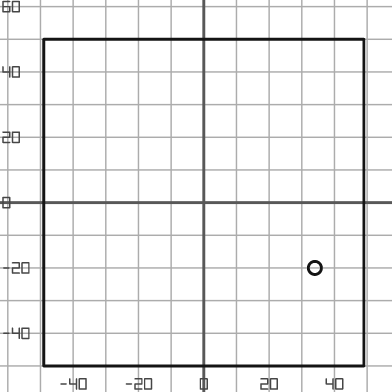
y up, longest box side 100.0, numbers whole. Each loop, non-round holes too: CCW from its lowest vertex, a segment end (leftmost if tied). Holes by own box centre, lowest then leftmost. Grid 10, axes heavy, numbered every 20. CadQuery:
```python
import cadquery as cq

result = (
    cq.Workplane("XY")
    .moveTo(-49.0, -50.0)
    .lineTo(49.0, -50.0)
    .lineTo(49.0, 50.0)
    .lineTo(-49.0, 50.0)
    .close()
    .moveTo(34.0, -20.0)
    .circle(2.0)
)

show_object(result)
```